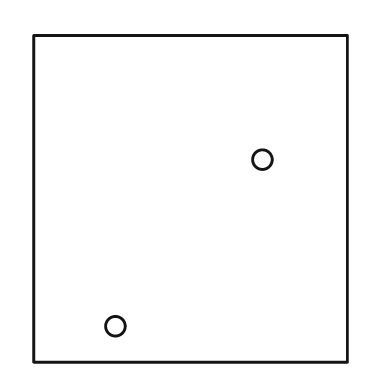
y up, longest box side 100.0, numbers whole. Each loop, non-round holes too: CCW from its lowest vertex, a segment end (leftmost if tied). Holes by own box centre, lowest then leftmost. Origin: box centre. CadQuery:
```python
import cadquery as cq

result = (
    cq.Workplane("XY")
    .moveTo(-48.0, -50.0)
    .lineTo(48.0, -50.0)
    .lineTo(48.0, 50.0)
    .lineTo(-48.0, 50.0)
    .close()
    .moveTo(-23.0, -39.0)
    .circle(3.0)
    .moveTo(22.0, 12.0)
    .circle(3.0)
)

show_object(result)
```